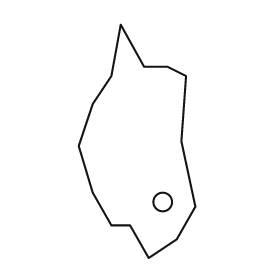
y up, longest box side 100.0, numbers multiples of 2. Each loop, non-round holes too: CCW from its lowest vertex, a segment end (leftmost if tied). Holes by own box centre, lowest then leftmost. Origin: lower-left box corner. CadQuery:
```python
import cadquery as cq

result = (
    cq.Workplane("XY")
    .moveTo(30.0, 0.0)
    .lineTo(42.0, 8.0)
    .lineTo(50.0, 22.0)
    .lineTo(44.0, 50.0)
    .lineTo(46.0, 78.0)
    .lineTo(38.0, 82.0)
    .lineTo(28.0, 82.0)
    .lineTo(18.0, 100.0)
    .lineTo(14.0, 78.0)
    .lineTo(6.0, 66.0)
    .lineTo(0.0, 48.0)
    .lineTo(6.0, 28.0)
    .lineTo(14.0, 14.0)
    .lineTo(22.0, 14.0)
    .close()
    .moveTo(36.0, 24.0)
    .circle(4.0)
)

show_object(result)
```